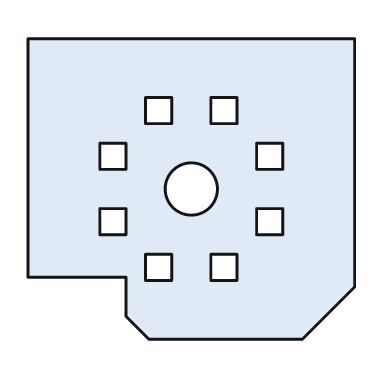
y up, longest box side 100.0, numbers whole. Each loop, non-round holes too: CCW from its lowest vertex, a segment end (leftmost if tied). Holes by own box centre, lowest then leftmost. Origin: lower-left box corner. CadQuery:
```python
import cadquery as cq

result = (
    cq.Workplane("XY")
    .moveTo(37.0, 0.0)
    .lineTo(84.0, 0.0)
    .lineTo(100.0, 16.0)
    .lineTo(100.0, 92.0)
    .lineTo(0.0, 92.0)
    .lineTo(0.0, 19.0)
    .lineTo(30.0, 19.0)
    .lineTo(30.0, 7.0)
    .close()
    .moveTo(36.0, 18.0)
    .lineTo(44.0, 18.0)
    .lineTo(44.0, 26.0)
    .lineTo(36.0, 26.0)
    .close()
    .moveTo(56.0, 18.0)
    .lineTo(64.0, 18.0)
    .lineTo(64.0, 26.0)
    .lineTo(56.0, 26.0)
    .close()
    .moveTo(22.0, 32.0)
    .lineTo(30.0, 32.0)
    .lineTo(30.0, 40.0)
    .lineTo(22.0, 40.0)
    .close()
    .moveTo(70.0, 32.0)
    .lineTo(78.0, 32.0)
    .lineTo(78.0, 40.0)
    .lineTo(70.0, 40.0)
    .close()
    .moveTo(50.0, 46.0)
    .circle(8.0)
    .moveTo(22.0, 52.0)
    .lineTo(30.0, 52.0)
    .lineTo(30.0, 60.0)
    .lineTo(22.0, 60.0)
    .close()
    .moveTo(70.0, 52.0)
    .lineTo(78.0, 52.0)
    .lineTo(78.0, 60.0)
    .lineTo(70.0, 60.0)
    .close()
    .moveTo(36.0, 66.0)
    .lineTo(44.0, 66.0)
    .lineTo(44.0, 74.0)
    .lineTo(36.0, 74.0)
    .close()
    .moveTo(56.0, 66.0)
    .lineTo(64.0, 66.0)
    .lineTo(64.0, 74.0)
    .lineTo(56.0, 74.0)
    .close()
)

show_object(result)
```